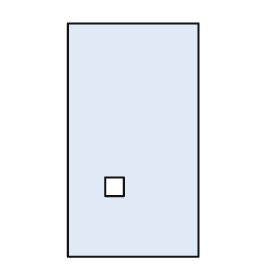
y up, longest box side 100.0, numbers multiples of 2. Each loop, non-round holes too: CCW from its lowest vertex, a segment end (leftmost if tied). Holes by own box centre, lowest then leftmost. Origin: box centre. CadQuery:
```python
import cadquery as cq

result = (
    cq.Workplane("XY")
    .moveTo(-28.0, -50.0)
    .lineTo(28.0, -50.0)
    .lineTo(28.0, 50.0)
    .lineTo(-28.0, 50.0)
    .close()
    .moveTo(-12.0, -24.0)
    .lineTo(-4.0, -24.0)
    .lineTo(-4.0, -16.0)
    .lineTo(-12.0, -16.0)
    .close()
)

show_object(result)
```